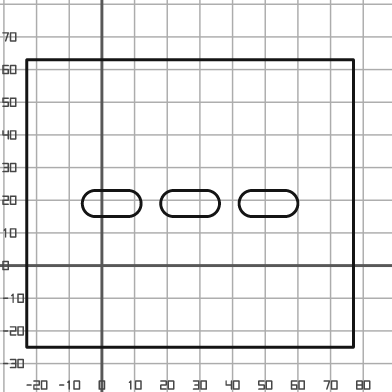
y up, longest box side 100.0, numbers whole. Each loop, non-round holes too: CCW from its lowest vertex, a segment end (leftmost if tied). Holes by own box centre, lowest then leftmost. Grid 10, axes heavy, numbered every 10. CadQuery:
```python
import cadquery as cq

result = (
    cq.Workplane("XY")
    .moveTo(-23.0, -25.0)
    .lineTo(77.0, -25.0)
    .lineTo(77.0, 63.0)
    .lineTo(-23.0, 63.0)
    .close()
    .moveTo(-2.0, 15.0)
    .lineTo(8.0, 15.0)
    .threePointArc((12.0, 19.0), (8.0, 23.0))
    .lineTo(-2.0, 23.0)
    .threePointArc((-6.0, 19.0), (-2.0, 15.0))
    .close()
    .moveTo(22.0, 15.0)
    .lineTo(32.0, 15.0)
    .threePointArc((36.0, 19.0), (32.0, 23.0))
    .lineTo(22.0, 23.0)
    .threePointArc((18.0, 19.0), (22.0, 15.0))
    .close()
    .moveTo(46.0, 15.0)
    .lineTo(56.0, 15.0)
    .threePointArc((60.0, 19.0), (56.0, 23.0))
    .lineTo(46.0, 23.0)
    .threePointArc((42.0, 19.0), (46.0, 15.0))
    .close()
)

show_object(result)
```